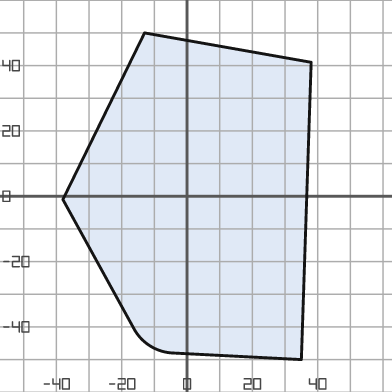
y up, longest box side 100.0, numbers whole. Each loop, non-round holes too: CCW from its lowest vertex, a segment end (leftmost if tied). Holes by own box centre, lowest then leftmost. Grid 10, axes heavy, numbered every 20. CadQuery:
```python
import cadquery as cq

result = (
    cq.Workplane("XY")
    .moveTo(35.0, -50.0)
    .lineTo(38.0, 41.0)
    .lineTo(-13.0, 50.0)
    .lineTo(-38.0, -1.0)
    .lineTo(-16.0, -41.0)
    .threePointArc((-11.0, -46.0), (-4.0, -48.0))
    .close()
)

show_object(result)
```